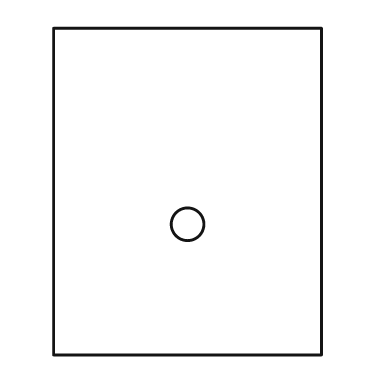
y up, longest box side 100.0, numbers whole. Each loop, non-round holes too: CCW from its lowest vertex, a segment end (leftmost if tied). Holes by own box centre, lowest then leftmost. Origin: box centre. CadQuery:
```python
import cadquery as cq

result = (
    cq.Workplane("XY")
    .moveTo(-41.0, -50.0)
    .lineTo(41.0, -50.0)
    .lineTo(41.0, 50.0)
    .lineTo(-41.0, 50.0)
    .close()
    .moveTo(0.0, -10.0)
    .circle(5.0)
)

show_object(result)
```